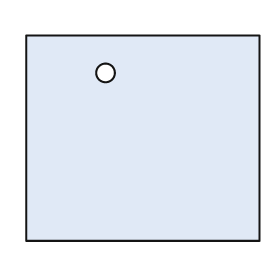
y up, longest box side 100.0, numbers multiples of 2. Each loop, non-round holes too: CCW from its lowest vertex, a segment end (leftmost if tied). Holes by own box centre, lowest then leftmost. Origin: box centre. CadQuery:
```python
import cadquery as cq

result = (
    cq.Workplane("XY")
    .moveTo(-50.0, -44.0)
    .lineTo(50.0, -44.0)
    .lineTo(50.0, 44.0)
    .lineTo(-50.0, 44.0)
    .close()
    .moveTo(-16.0, 28.0)
    .circle(4.0)
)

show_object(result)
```